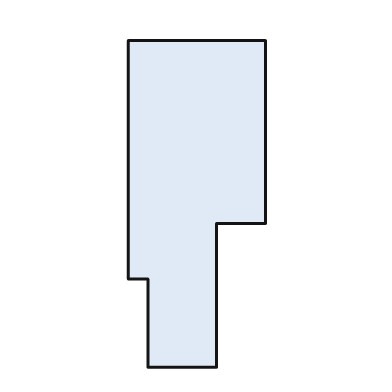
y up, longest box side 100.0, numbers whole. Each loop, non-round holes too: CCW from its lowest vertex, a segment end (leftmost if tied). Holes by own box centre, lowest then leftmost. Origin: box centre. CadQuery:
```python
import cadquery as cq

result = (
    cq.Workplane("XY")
    .moveTo(-15.0, -50.0)
    .lineTo(6.0, -50.0)
    .lineTo(6.0, -6.0)
    .lineTo(21.0, -6.0)
    .lineTo(21.0, 50.0)
    .lineTo(-21.0, 50.0)
    .lineTo(-21.0, -23.0)
    .lineTo(-15.0, -23.0)
    .close()
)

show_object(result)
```